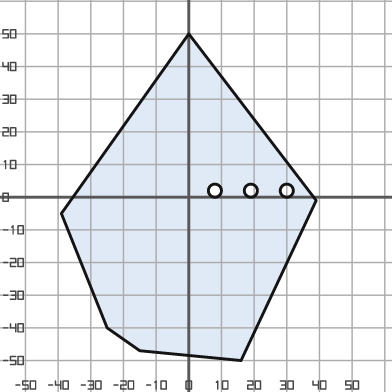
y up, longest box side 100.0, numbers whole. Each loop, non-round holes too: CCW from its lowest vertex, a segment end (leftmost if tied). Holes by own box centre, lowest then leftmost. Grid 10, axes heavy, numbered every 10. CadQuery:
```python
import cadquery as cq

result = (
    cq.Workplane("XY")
    .moveTo(16.0, -50.0)
    .lineTo(39.0, -1.0)
    .lineTo(0.0, 50.0)
    .lineTo(-39.0, -5.0)
    .lineTo(-25.0, -40.0)
    .lineTo(-15.0, -47.0)
    .close()
    .moveTo(8.0, 2.0)
    .circle(2.0)
    .moveTo(19.0, 2.0)
    .circle(2.0)
    .moveTo(30.0, 2.0)
    .circle(2.0)
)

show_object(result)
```